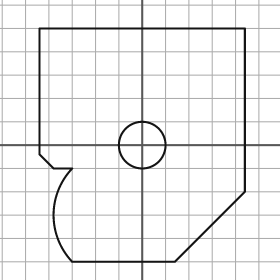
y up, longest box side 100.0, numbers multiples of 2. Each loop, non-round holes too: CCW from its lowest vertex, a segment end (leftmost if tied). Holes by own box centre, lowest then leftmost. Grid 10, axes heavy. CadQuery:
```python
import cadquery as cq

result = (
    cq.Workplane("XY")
    .moveTo(-30.0, -50.0)
    .lineTo(14.0, -50.0)
    .lineTo(44.0, -20.0)
    .lineTo(44.0, 50.0)
    .lineTo(-44.0, 50.0)
    .lineTo(-44.0, -4.0)
    .lineTo(-38.0, -10.0)
    .lineTo(-30.0, -10.0)
    .threePointArc((-38.0, -30.0), (-30.0, -50.0))
    .close()
    .moveTo(0.0, 0.0)
    .circle(10.0)
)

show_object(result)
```